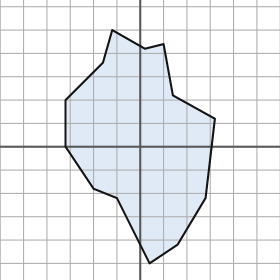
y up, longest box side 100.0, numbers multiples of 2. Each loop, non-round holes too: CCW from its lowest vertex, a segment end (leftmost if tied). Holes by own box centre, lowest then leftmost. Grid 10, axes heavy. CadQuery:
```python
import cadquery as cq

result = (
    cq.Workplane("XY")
    .moveTo(4.0, -50.0)
    .lineTo(16.0, -42.0)
    .lineTo(28.0, -22.0)
    .lineTo(32.0, 12.0)
    .lineTo(14.0, 22.0)
    .lineTo(10.0, 44.0)
    .lineTo(2.0, 42.0)
    .lineTo(-12.0, 50.0)
    .lineTo(-16.0, 36.0)
    .lineTo(-32.0, 20.0)
    .lineTo(-32.0, 0.0)
    .lineTo(-20.0, -18.0)
    .lineTo(-10.0, -22.0)
    .close()
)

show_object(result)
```